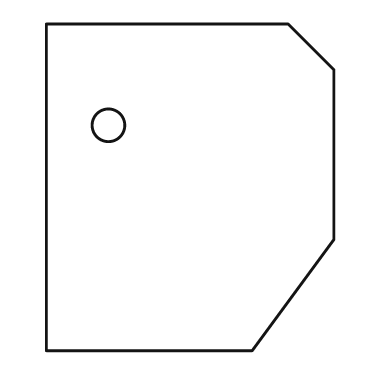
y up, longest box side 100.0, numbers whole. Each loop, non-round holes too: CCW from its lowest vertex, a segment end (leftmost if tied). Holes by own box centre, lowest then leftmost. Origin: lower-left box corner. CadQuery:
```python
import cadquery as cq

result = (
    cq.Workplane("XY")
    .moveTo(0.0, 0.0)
    .lineTo(63.0, 0.0)
    .lineTo(88.0, 34.0)
    .lineTo(88.0, 86.0)
    .lineTo(74.0, 100.0)
    .lineTo(0.0, 100.0)
    .close()
    .moveTo(19.0, 69.0)
    .circle(5.0)
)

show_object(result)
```